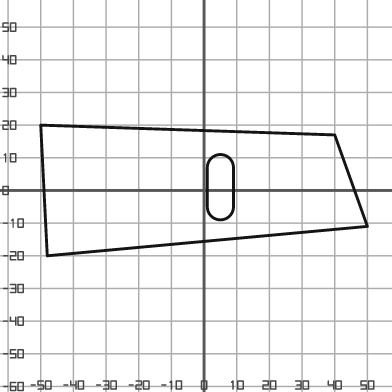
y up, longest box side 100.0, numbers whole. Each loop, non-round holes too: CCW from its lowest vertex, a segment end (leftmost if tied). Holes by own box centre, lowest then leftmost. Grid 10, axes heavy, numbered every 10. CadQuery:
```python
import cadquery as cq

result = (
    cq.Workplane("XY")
    .moveTo(-48.0, -20.0)
    .lineTo(50.0, -11.0)
    .lineTo(40.0, 17.0)
    .lineTo(-50.0, 20.0)
    .close()
    .moveTo(1.0, -5.0)
    .threePointArc((5.0, -9.0), (9.0, -5.0))
    .lineTo(9.0, 7.0)
    .threePointArc((5.0, 11.0), (1.0, 7.0))
    .close()
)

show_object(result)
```